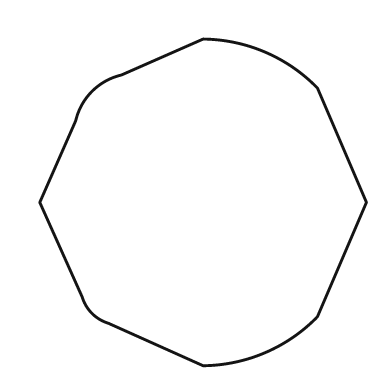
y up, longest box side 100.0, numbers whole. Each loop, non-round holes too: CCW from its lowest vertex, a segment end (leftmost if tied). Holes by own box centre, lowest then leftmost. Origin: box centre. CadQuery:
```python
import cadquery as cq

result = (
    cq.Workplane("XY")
    .moveTo(0.0, -50.0)
    .threePointArc((19.0, -46.0), (35.0, -35.0))
    .lineTo(50.0, 0.0)
    .lineTo(35.0, 35.0)
    .threePointArc((19.0, 46.0), (0.0, 50.0))
    .lineTo(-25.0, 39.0)
    .threePointArc((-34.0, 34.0), (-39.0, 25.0))
    .lineTo(-50.0, 0.0)
    .lineTo(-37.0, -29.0)
    .threePointArc((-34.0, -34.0), (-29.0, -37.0))
    .close()
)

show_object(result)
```